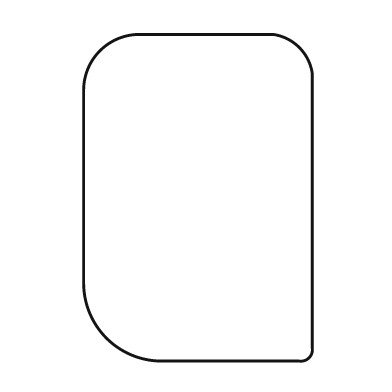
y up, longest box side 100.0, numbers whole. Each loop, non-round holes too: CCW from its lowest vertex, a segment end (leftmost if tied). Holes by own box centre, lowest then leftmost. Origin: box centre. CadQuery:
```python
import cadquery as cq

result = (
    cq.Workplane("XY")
    .moveTo(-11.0, -50.0)
    .lineTo(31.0, -50.0)
    .threePointArc((34.0, -49.0), (35.0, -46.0))
    .lineTo(35.0, 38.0)
    .threePointArc((31.0, 46.0), (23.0, 50.0))
    .lineTo(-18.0, 50.0)
    .threePointArc((-30.0, 45.0), (-35.0, 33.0))
    .lineTo(-35.0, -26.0)
    .threePointArc((-28.0, -43.0), (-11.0, -50.0))
    .close()
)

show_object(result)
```